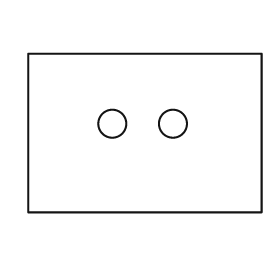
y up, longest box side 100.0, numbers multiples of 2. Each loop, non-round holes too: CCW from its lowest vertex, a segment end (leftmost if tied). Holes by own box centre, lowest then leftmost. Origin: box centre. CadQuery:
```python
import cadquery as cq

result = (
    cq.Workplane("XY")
    .moveTo(-50.0, -34.0)
    .lineTo(50.0, -34.0)
    .lineTo(50.0, 34.0)
    .lineTo(-50.0, 34.0)
    .close()
    .moveTo(-14.0, 4.0)
    .circle(6.0)
    .moveTo(12.0, 4.0)
    .circle(6.0)
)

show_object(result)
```